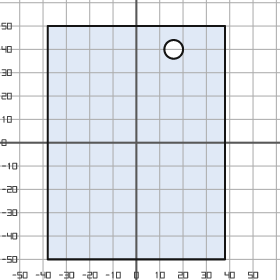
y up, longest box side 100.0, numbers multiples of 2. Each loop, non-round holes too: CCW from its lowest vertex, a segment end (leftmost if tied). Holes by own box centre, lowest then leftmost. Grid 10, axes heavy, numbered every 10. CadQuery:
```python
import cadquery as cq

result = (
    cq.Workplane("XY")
    .moveTo(-38.0, -50.0)
    .lineTo(38.0, -50.0)
    .lineTo(38.0, 50.0)
    .lineTo(-38.0, 50.0)
    .close()
    .moveTo(16.0, 40.0)
    .circle(4.0)
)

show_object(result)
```